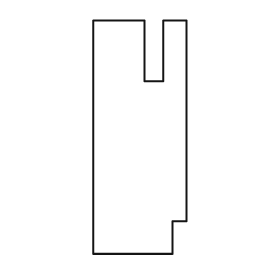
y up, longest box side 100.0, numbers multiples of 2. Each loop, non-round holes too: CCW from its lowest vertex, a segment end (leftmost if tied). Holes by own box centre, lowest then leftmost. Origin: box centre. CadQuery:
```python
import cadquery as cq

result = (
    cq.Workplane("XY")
    .moveTo(-20.0, -50.0)
    .lineTo(14.0, -50.0)
    .lineTo(14.0, -36.0)
    .lineTo(20.0, -36.0)
    .lineTo(20.0, 50.0)
    .lineTo(10.0, 50.0)
    .lineTo(10.0, 24.0)
    .lineTo(2.0, 24.0)
    .lineTo(2.0, 50.0)
    .lineTo(-20.0, 50.0)
    .close()
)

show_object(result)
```